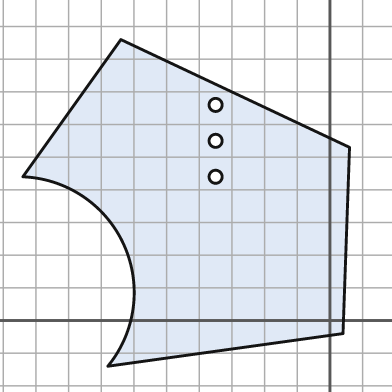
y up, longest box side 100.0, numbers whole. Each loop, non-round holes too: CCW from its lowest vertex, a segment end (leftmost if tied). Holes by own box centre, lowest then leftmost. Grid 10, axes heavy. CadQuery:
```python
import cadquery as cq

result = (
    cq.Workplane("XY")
    .moveTo(-68.0, -14.0)
    .lineTo(4.0, -4.0)
    .lineTo(6.0, 53.0)
    .lineTo(-64.0, 86.0)
    .lineTo(-94.0, 44.0)
    .threePointArc((-63.0, 23.0), (-68.0, -14.0))
    .close()
    .moveTo(-35.0, 44.0)
    .circle(2.0)
    .moveTo(-35.0, 55.0)
    .circle(2.0)
    .moveTo(-35.0, 66.0)
    .circle(2.0)
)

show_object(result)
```